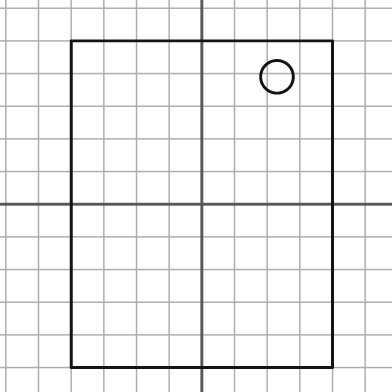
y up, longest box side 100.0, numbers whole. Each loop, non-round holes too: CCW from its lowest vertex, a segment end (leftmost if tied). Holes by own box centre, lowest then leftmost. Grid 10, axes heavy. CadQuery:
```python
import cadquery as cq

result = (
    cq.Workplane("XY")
    .moveTo(-40.0, -50.0)
    .lineTo(40.0, -50.0)
    .lineTo(40.0, 50.0)
    .lineTo(-40.0, 50.0)
    .close()
    .moveTo(23.0, 39.0)
    .circle(5.0)
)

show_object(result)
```